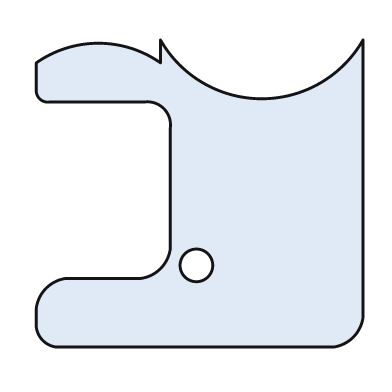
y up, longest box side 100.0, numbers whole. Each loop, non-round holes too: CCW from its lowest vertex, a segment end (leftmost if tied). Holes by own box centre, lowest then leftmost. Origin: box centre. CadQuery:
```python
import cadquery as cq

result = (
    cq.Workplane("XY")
    .moveTo(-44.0, -47.0)
    .lineTo(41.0, -47.0)
    .threePointArc((47.0, -44.0), (50.0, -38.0))
    .lineTo(50.0, 47.0)
    .threePointArc((19.0, 29.0), (-12.0, 47.0))
    .lineTo(-12.0, 40.0)
    .threePointArc((-31.0, 46.0), (-50.0, 40.0))
    .lineTo(-50.0, 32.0)
    .threePointArc((-49.0, 29.0), (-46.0, 28.0))
    .lineTo(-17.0, 28.0)
    .threePointArc((-11.0, 26.0), (-9.0, 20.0))
    .lineTo(-9.0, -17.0)
    .threePointArc((-12.0, -23.0), (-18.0, -26.0))
    .lineTo(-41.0, -26.0)
    .threePointArc((-47.0, -29.0), (-50.0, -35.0))
    .lineTo(-50.0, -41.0)
    .threePointArc((-48.0, -45.0), (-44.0, -47.0))
    .close()
    .moveTo(-1.0, -22.0)
    .circle(5.0)
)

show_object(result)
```